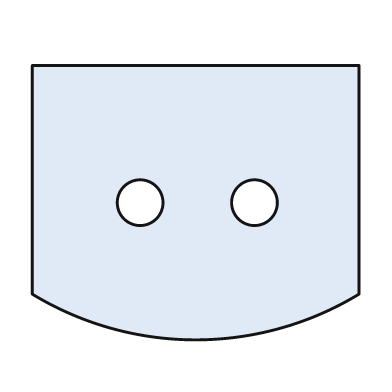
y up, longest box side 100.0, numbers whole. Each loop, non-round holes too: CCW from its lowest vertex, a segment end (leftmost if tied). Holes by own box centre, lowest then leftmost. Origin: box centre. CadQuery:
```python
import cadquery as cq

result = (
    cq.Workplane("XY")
    .moveTo(-50.0, -28.0)
    .threePointArc((0.0, -42.0), (50.0, -28.0))
    .lineTo(50.0, 42.0)
    .lineTo(-50.0, 42.0)
    .close()
    .moveTo(-17.0, 0.0)
    .circle(7.0)
    .moveTo(18.0, 0.0)
    .circle(7.0)
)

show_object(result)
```